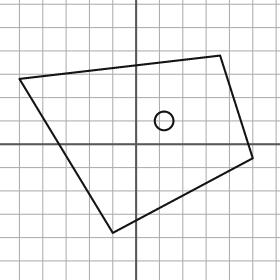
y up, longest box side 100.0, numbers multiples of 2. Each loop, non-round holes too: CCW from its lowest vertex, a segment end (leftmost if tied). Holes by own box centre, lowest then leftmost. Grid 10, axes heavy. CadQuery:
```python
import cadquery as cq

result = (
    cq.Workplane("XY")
    .moveTo(-10.0, -38.0)
    .lineTo(50.0, -6.0)
    .lineTo(36.0, 38.0)
    .lineTo(-50.0, 28.0)
    .close()
    .moveTo(12.0, 10.0)
    .circle(4.0)
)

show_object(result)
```